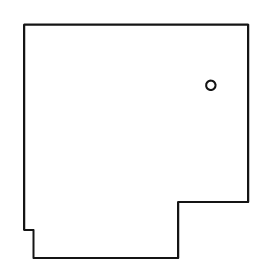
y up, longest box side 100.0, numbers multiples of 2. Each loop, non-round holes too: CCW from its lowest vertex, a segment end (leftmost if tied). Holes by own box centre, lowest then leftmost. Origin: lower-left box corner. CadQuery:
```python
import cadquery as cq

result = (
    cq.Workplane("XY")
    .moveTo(4.0, 0.0)
    .lineTo(66.0, 0.0)
    .lineTo(66.0, 24.0)
    .lineTo(96.0, 24.0)
    .lineTo(96.0, 100.0)
    .lineTo(0.0, 100.0)
    .lineTo(0.0, 12.0)
    .lineTo(4.0, 12.0)
    .close()
    .moveTo(80.0, 74.0)
    .circle(2.0)
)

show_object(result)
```